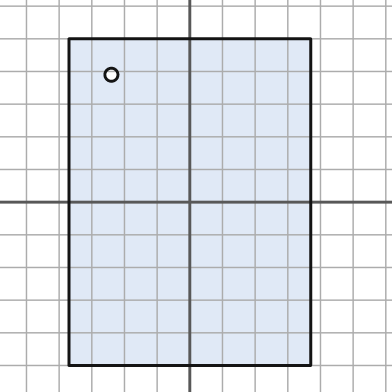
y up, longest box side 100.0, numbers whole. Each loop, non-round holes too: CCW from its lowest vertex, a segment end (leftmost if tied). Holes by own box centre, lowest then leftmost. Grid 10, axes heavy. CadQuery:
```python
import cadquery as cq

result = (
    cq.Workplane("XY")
    .moveTo(-37.0, -50.0)
    .lineTo(37.0, -50.0)
    .lineTo(37.0, 50.0)
    .lineTo(-37.0, 50.0)
    .close()
    .moveTo(-24.0, 39.0)
    .circle(2.0)
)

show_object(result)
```